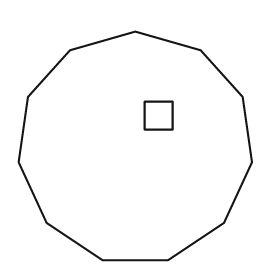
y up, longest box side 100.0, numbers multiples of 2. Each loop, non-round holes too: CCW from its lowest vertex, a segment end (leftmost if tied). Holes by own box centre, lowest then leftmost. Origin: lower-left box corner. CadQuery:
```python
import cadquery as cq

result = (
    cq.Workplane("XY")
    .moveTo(36.0, 0.0)
    .lineTo(64.0, 0.0)
    .lineTo(88.0, 16.0)
    .lineTo(100.0, 42.0)
    .lineTo(96.0, 70.0)
    .lineTo(78.0, 90.0)
    .lineTo(50.0, 98.0)
    .lineTo(22.0, 90.0)
    .lineTo(4.0, 70.0)
    .lineTo(0.0, 42.0)
    .lineTo(12.0, 16.0)
    .close()
    .moveTo(54.0, 56.0)
    .lineTo(66.0, 56.0)
    .lineTo(66.0, 68.0)
    .lineTo(54.0, 68.0)
    .close()
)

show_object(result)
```